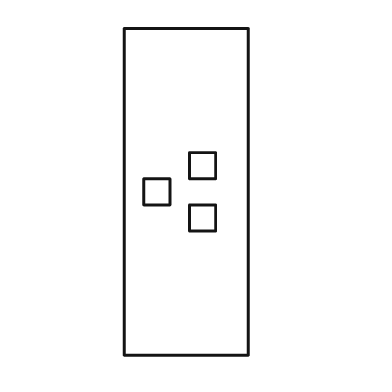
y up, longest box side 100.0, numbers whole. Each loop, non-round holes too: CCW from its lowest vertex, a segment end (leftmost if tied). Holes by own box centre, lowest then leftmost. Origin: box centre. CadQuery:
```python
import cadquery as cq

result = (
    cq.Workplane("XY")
    .moveTo(-19.0, -50.0)
    .lineTo(19.0, -50.0)
    .lineTo(19.0, 50.0)
    .lineTo(-19.0, 50.0)
    .close()
    .moveTo(1.0, -12.0)
    .lineTo(9.0, -12.0)
    .lineTo(9.0, -4.0)
    .lineTo(1.0, -4.0)
    .close()
    .moveTo(-13.0, -4.0)
    .lineTo(-5.0, -4.0)
    .lineTo(-5.0, 4.0)
    .lineTo(-13.0, 4.0)
    .close()
    .moveTo(1.0, 4.0)
    .lineTo(9.0, 4.0)
    .lineTo(9.0, 12.0)
    .lineTo(1.0, 12.0)
    .close()
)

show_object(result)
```